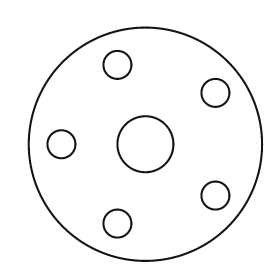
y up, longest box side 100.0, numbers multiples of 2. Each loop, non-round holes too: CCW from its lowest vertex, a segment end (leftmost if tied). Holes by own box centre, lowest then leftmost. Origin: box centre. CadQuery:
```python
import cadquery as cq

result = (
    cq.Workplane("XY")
    .moveTo(0.0, 0.0)
    .circle(50.0)
    .moveTo(-12.0, -34.0)
    .circle(6.0)
    .moveTo(30.0, -22.0)
    .circle(6.0)
    .moveTo(-36.0, 0.0)
    .circle(6.0)
    .moveTo(0.0, 0.0)
    .circle(12.0)
    .moveTo(30.0, 22.0)
    .circle(6.0)
    .moveTo(-12.0, 34.0)
    .circle(6.0)
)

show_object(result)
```